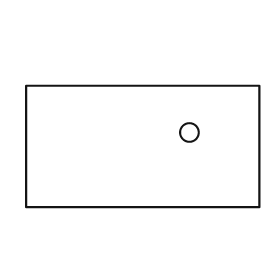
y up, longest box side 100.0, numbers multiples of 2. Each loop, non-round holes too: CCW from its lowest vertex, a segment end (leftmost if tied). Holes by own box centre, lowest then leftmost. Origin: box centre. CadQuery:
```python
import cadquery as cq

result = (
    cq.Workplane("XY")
    .moveTo(-50.0, -26.0)
    .lineTo(50.0, -26.0)
    .lineTo(50.0, 26.0)
    .lineTo(-50.0, 26.0)
    .close()
    .moveTo(20.0, 6.0)
    .circle(4.0)
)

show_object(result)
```